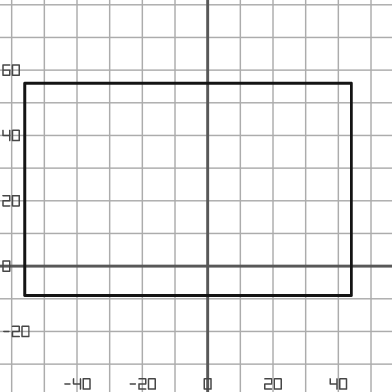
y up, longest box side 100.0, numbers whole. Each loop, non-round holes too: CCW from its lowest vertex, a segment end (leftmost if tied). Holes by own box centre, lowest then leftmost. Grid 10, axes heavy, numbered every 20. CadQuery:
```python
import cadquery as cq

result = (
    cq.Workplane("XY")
    .moveTo(-56.0, -9.0)
    .lineTo(44.0, -9.0)
    .lineTo(44.0, 56.0)
    .lineTo(-56.0, 56.0)
    .close()
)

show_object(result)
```